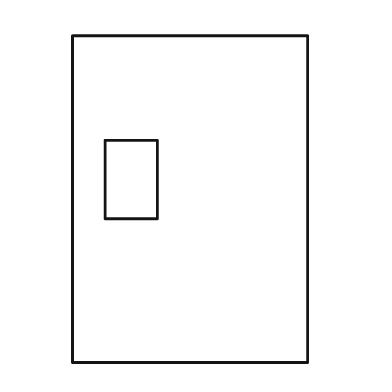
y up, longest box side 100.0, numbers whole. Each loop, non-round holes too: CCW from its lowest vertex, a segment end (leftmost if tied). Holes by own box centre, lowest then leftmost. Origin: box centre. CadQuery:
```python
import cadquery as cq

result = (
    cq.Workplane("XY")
    .moveTo(-36.0, -50.0)
    .lineTo(36.0, -50.0)
    .lineTo(36.0, 50.0)
    .lineTo(-36.0, 50.0)
    .close()
    .moveTo(-26.0, -6.0)
    .lineTo(-10.0, -6.0)
    .lineTo(-10.0, 18.0)
    .lineTo(-26.0, 18.0)
    .close()
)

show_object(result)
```